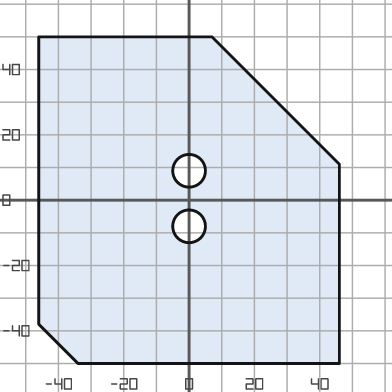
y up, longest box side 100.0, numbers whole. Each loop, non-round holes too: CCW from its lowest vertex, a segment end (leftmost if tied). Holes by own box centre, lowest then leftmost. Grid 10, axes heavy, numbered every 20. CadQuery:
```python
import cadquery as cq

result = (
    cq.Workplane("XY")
    .moveTo(-34.0, -50.0)
    .lineTo(46.0, -50.0)
    .lineTo(46.0, 11.0)
    .lineTo(7.0, 50.0)
    .lineTo(-46.0, 50.0)
    .lineTo(-46.0, -38.0)
    .close()
    .moveTo(0.0, -8.0)
    .circle(5.0)
    .moveTo(0.0, 9.0)
    .circle(5.0)
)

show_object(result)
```